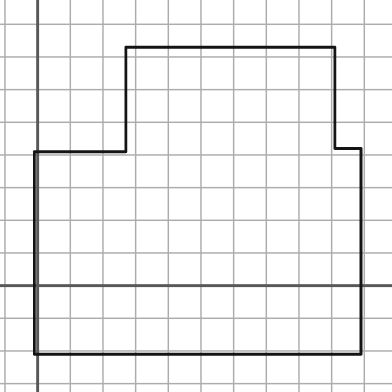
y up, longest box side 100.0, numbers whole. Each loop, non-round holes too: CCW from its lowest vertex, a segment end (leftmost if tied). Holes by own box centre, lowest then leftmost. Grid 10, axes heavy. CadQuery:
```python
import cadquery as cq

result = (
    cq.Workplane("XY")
    .moveTo(-1.0, -21.0)
    .lineTo(99.0, -21.0)
    .lineTo(99.0, 42.0)
    .lineTo(91.0, 42.0)
    .lineTo(91.0, 73.0)
    .lineTo(27.0, 73.0)
    .lineTo(27.0, 41.0)
    .lineTo(-1.0, 41.0)
    .close()
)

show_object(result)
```